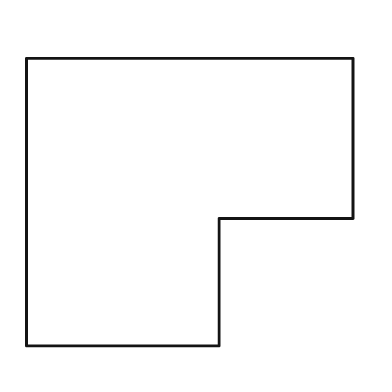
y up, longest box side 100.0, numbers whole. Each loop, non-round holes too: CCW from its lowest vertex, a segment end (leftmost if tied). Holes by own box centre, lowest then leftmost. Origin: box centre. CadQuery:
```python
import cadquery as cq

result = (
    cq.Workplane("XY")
    .moveTo(-50.0, -44.0)
    .lineTo(9.0, -44.0)
    .lineTo(9.0, -5.0)
    .lineTo(50.0, -5.0)
    .lineTo(50.0, 44.0)
    .lineTo(-50.0, 44.0)
    .close()
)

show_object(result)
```